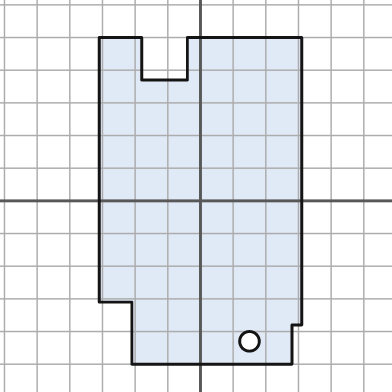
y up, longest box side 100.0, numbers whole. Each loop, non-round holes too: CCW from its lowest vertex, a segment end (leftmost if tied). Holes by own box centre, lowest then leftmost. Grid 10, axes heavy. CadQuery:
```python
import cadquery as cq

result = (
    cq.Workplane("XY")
    .moveTo(-21.0, -50.0)
    .lineTo(28.0, -50.0)
    .lineTo(28.0, -38.0)
    .lineTo(31.0, -38.0)
    .lineTo(31.0, 50.0)
    .lineTo(-4.0, 50.0)
    .lineTo(-4.0, 37.0)
    .lineTo(-18.0, 37.0)
    .lineTo(-18.0, 50.0)
    .lineTo(-31.0, 50.0)
    .lineTo(-31.0, -31.0)
    .lineTo(-21.0, -31.0)
    .close()
    .moveTo(15.0, -43.0)
    .circle(3.0)
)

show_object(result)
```